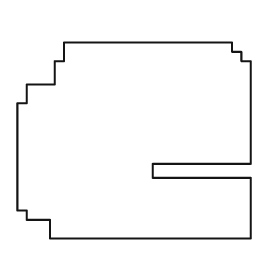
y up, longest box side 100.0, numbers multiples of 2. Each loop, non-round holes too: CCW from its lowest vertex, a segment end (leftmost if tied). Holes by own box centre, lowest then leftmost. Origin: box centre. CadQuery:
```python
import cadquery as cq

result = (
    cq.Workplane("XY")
    .moveTo(-36.0, -42.0)
    .lineTo(50.0, -42.0)
    .lineTo(50.0, -16.0)
    .lineTo(8.0, -16.0)
    .lineTo(8.0, -10.0)
    .lineTo(50.0, -10.0)
    .lineTo(50.0, 34.0)
    .lineTo(46.0, 34.0)
    .lineTo(46.0, 38.0)
    .lineTo(42.0, 38.0)
    .lineTo(42.0, 42.0)
    .lineTo(-30.0, 42.0)
    .lineTo(-30.0, 34.0)
    .lineTo(-34.0, 34.0)
    .lineTo(-34.0, 24.0)
    .lineTo(-46.0, 24.0)
    .lineTo(-46.0, 16.0)
    .lineTo(-50.0, 16.0)
    .lineTo(-50.0, -30.0)
    .lineTo(-46.0, -30.0)
    .lineTo(-46.0, -34.0)
    .lineTo(-36.0, -34.0)
    .close()
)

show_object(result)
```